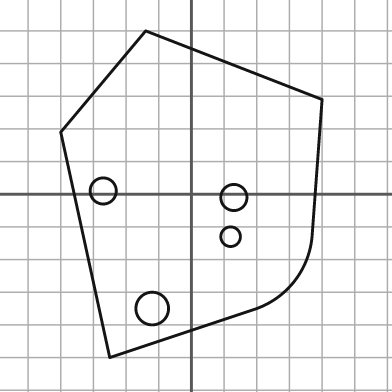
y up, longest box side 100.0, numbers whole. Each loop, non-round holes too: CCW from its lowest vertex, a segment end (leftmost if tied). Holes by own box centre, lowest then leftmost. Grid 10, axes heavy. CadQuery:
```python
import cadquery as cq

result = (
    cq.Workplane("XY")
    .moveTo(-25.0, -50.0)
    .lineTo(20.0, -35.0)
    .threePointArc((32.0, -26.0), (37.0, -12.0))
    .lineTo(40.0, 29.0)
    .lineTo(-14.0, 50.0)
    .lineTo(-40.0, 19.0)
    .close()
    .moveTo(-12.0, -35.0)
    .circle(5.0)
    .moveTo(12.0, -13.0)
    .circle(3.0)
    .moveTo(13.0, -1.0)
    .circle(4.0)
    .moveTo(-27.0, 1.0)
    .circle(4.0)
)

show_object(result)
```